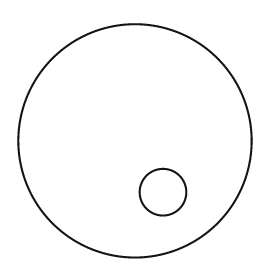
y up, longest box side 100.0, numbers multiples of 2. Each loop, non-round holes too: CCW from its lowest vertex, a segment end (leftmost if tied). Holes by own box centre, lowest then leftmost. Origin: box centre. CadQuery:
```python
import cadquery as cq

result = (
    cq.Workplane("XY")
    .moveTo(0.0, 0.0)
    .circle(50.0)
    .moveTo(12.0, -22.0)
    .circle(10.0)
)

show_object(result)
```